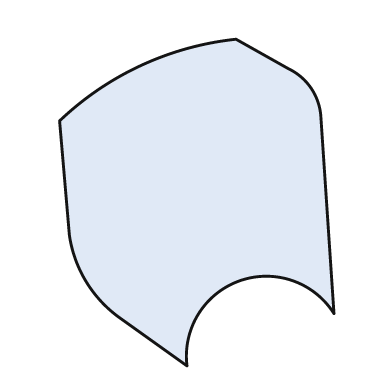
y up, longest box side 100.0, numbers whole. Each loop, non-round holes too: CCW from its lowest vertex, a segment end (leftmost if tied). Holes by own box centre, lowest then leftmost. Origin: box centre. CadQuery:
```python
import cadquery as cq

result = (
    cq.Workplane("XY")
    .moveTo(-3.0, -50.0)
    .threePointArc((13.0, -24.0), (42.0, -34.0))
    .lineTo(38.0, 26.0)
    .threePointArc((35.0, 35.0), (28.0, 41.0))
    .lineTo(12.0, 50.0)
    .threePointArc((-17.0, 42.0), (-42.0, 25.0))
    .lineTo(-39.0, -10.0)
    .threePointArc((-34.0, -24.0), (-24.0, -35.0))
    .close()
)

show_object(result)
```